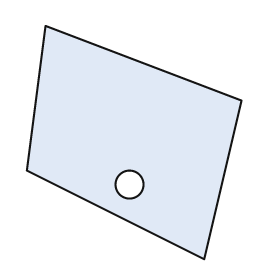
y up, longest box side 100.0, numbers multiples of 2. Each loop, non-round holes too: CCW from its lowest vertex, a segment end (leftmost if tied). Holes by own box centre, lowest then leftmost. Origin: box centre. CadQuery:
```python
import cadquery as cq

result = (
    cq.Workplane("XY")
    .moveTo(30.0, -50.0)
    .lineTo(46.0, 18.0)
    .lineTo(-38.0, 50.0)
    .lineTo(-46.0, -12.0)
    .close()
    .moveTo(-2.0, -18.0)
    .circle(6.0)
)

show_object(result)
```